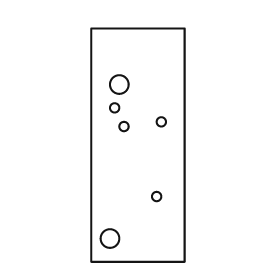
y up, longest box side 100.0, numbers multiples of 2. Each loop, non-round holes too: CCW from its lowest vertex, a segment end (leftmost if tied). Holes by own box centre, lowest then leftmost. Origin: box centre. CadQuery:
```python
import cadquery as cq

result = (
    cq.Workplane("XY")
    .moveTo(-20.0, -50.0)
    .lineTo(20.0, -50.0)
    .lineTo(20.0, 50.0)
    .lineTo(-20.0, 50.0)
    .close()
    .moveTo(-12.0, -40.0)
    .circle(4.0)
    .moveTo(8.0, -22.0)
    .circle(2.0)
    .moveTo(-6.0, 8.0)
    .circle(2.0)
    .moveTo(10.0, 10.0)
    .circle(2.0)
    .moveTo(-10.0, 16.0)
    .circle(2.0)
    .moveTo(-8.0, 26.0)
    .circle(4.0)
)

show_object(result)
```